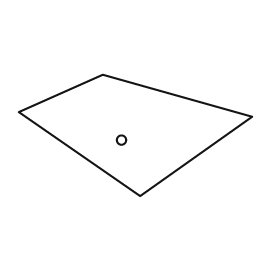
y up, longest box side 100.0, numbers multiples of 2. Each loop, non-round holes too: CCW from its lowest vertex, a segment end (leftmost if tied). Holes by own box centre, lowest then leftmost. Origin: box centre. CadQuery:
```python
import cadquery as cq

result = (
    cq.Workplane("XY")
    .moveTo(2.0, -26.0)
    .lineTo(50.0, 8.0)
    .lineTo(-14.0, 26.0)
    .lineTo(-50.0, 10.0)
    .close()
    .moveTo(-6.0, -2.0)
    .circle(2.0)
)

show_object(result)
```